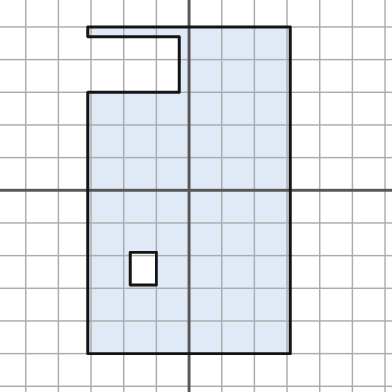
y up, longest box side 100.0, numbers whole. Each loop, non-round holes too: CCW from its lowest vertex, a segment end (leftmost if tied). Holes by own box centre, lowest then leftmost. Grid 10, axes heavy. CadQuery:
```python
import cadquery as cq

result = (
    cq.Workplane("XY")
    .moveTo(-31.0, -50.0)
    .lineTo(31.0, -50.0)
    .lineTo(31.0, 50.0)
    .lineTo(-31.0, 50.0)
    .lineTo(-31.0, 47.0)
    .lineTo(-3.0, 47.0)
    .lineTo(-3.0, 30.0)
    .lineTo(-31.0, 30.0)
    .close()
    .moveTo(-18.0, -29.0)
    .lineTo(-10.0, -29.0)
    .lineTo(-10.0, -19.0)
    .lineTo(-18.0, -19.0)
    .close()
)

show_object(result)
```